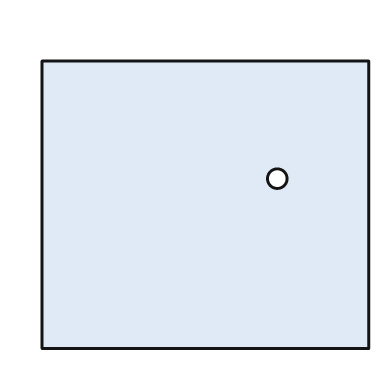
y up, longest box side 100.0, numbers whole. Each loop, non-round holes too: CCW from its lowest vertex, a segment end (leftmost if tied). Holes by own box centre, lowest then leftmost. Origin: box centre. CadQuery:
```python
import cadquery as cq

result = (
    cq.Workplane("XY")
    .moveTo(-50.0, -44.0)
    .lineTo(50.0, -44.0)
    .lineTo(50.0, 44.0)
    .lineTo(-50.0, 44.0)
    .close()
    .moveTo(22.0, 8.0)
    .circle(3.0)
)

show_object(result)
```